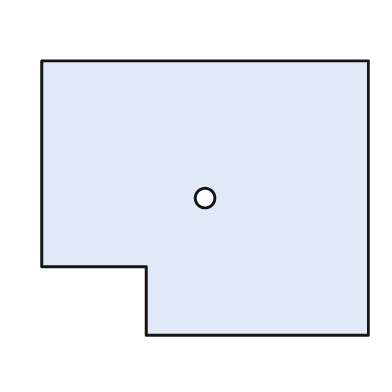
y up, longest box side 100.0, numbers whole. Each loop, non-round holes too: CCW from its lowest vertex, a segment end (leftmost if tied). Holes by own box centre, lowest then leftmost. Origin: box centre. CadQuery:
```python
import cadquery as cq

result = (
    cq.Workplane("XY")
    .moveTo(-18.0, -42.0)
    .lineTo(50.0, -42.0)
    .lineTo(50.0, 42.0)
    .lineTo(-50.0, 42.0)
    .lineTo(-50.0, -21.0)
    .lineTo(-18.0, -21.0)
    .close()
    .moveTo(0.0, 0.0)
    .circle(3.0)
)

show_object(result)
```